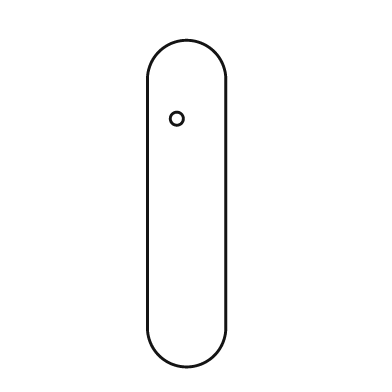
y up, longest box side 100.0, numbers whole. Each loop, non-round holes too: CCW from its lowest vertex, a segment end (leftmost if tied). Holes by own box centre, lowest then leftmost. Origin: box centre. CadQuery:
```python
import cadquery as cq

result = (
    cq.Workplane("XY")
    .moveTo(-12.0, -38.0)
    .threePointArc((0.0, -50.0), (12.0, -38.0))
    .lineTo(12.0, 38.0)
    .threePointArc((0.0, 50.0), (-12.0, 38.0))
    .close()
    .moveTo(-3.0, 26.0)
    .circle(2.0)
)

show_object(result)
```